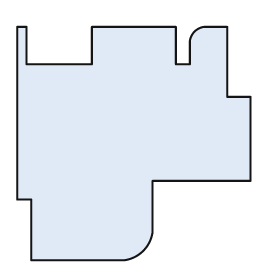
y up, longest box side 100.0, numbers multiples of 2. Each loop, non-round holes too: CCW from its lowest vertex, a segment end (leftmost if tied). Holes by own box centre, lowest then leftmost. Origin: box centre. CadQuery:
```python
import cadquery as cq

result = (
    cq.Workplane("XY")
    .moveTo(-44.0, -50.0)
    .lineTo(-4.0, -50.0)
    .threePointArc((4.0, -46.0), (8.0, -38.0))
    .lineTo(8.0, -16.0)
    .lineTo(50.0, -16.0)
    .lineTo(50.0, 20.0)
    .lineTo(40.0, 20.0)
    .lineTo(40.0, 50.0)
    .lineTo(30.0, 50.0)
    .threePointArc((26.0, 48.0), (24.0, 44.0))
    .lineTo(24.0, 34.0)
    .lineTo(18.0, 34.0)
    .lineTo(18.0, 50.0)
    .lineTo(-18.0, 50.0)
    .lineTo(-18.0, 34.0)
    .lineTo(-46.0, 34.0)
    .lineTo(-46.0, 50.0)
    .lineTo(-50.0, 50.0)
    .lineTo(-50.0, -24.0)
    .lineTo(-44.0, -24.0)
    .close()
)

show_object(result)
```